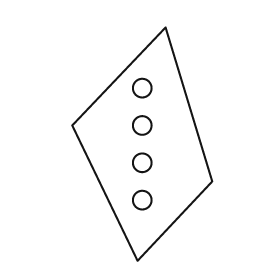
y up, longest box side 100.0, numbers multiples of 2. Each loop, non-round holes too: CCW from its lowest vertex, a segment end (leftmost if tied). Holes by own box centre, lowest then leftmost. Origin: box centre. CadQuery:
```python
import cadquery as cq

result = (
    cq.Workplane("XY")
    .moveTo(-2.0, -50.0)
    .lineTo(30.0, -16.0)
    .lineTo(10.0, 50.0)
    .lineTo(-30.0, 8.0)
    .close()
    .moveTo(0.0, -24.0)
    .circle(4.0)
    .moveTo(0.0, -8.0)
    .circle(4.0)
    .moveTo(0.0, 8.0)
    .circle(4.0)
    .moveTo(0.0, 24.0)
    .circle(4.0)
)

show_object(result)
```